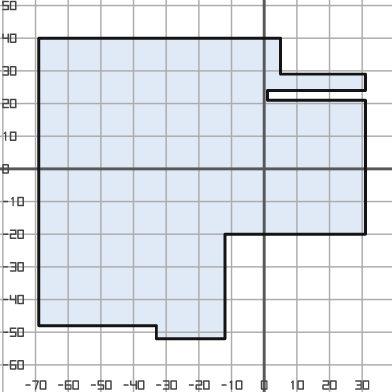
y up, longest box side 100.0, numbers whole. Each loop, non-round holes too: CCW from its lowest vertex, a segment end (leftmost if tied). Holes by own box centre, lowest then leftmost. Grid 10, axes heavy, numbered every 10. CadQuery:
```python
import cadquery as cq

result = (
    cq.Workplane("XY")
    .moveTo(-33.0, -52.0)
    .lineTo(-12.0, -52.0)
    .lineTo(-12.0, -20.0)
    .lineTo(31.0, -20.0)
    .lineTo(31.0, 21.0)
    .lineTo(1.0, 21.0)
    .lineTo(1.0, 24.0)
    .lineTo(31.0, 24.0)
    .lineTo(31.0, 29.0)
    .lineTo(5.0, 29.0)
    .lineTo(5.0, 40.0)
    .lineTo(-69.0, 40.0)
    .lineTo(-69.0, -48.0)
    .lineTo(-33.0, -48.0)
    .close()
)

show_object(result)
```